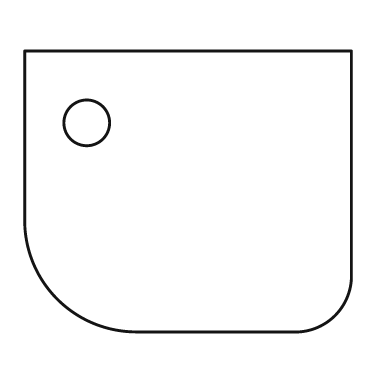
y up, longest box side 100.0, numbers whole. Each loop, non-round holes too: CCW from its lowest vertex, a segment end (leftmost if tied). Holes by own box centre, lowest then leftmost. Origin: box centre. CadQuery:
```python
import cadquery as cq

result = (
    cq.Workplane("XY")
    .moveTo(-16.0, -43.0)
    .lineTo(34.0, -43.0)
    .threePointArc((45.0, -38.0), (50.0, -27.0))
    .lineTo(50.0, 43.0)
    .lineTo(-50.0, 43.0)
    .lineTo(-50.0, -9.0)
    .threePointArc((-40.0, -33.0), (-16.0, -43.0))
    .close()
    .moveTo(-31.0, 21.0)
    .circle(7.0)
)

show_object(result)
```